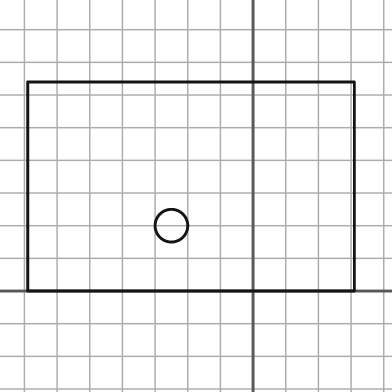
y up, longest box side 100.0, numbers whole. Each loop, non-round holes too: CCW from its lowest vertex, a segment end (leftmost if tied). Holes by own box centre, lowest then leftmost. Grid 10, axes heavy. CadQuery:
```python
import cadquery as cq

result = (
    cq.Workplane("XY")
    .moveTo(-69.0, 0.0)
    .lineTo(31.0, 0.0)
    .lineTo(31.0, 64.0)
    .lineTo(-69.0, 64.0)
    .close()
    .moveTo(-25.0, 20.0)
    .circle(5.0)
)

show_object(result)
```